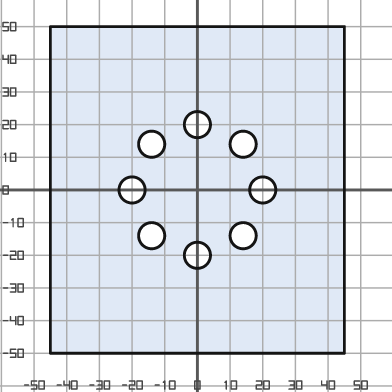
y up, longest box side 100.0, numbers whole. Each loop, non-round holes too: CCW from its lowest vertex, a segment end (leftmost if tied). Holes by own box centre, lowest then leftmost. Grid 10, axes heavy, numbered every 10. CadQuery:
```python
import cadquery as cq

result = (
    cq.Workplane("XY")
    .moveTo(-45.0, -50.0)
    .lineTo(45.0, -50.0)
    .lineTo(45.0, 50.0)
    .lineTo(-45.0, 50.0)
    .close()
    .moveTo(0.0, -20.0)
    .circle(4.0)
    .moveTo(-14.0, -14.0)
    .circle(4.0)
    .moveTo(14.0, -14.0)
    .circle(4.0)
    .moveTo(-20.0, 0.0)
    .circle(4.0)
    .moveTo(20.0, 0.0)
    .circle(4.0)
    .moveTo(-14.0, 14.0)
    .circle(4.0)
    .moveTo(14.0, 14.0)
    .circle(4.0)
    .moveTo(0.0, 20.0)
    .circle(4.0)
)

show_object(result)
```